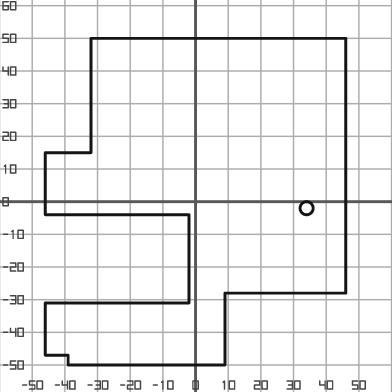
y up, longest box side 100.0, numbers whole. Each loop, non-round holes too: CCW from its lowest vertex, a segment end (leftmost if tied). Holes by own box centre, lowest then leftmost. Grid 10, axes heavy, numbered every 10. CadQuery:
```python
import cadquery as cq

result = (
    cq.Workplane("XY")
    .moveTo(-39.0, -50.0)
    .lineTo(9.0, -50.0)
    .lineTo(9.0, -28.0)
    .lineTo(46.0, -28.0)
    .lineTo(46.0, 50.0)
    .lineTo(-32.0, 50.0)
    .lineTo(-32.0, 15.0)
    .lineTo(-46.0, 15.0)
    .lineTo(-46.0, -4.0)
    .lineTo(-2.0, -4.0)
    .lineTo(-2.0, -31.0)
    .lineTo(-46.0, -31.0)
    .lineTo(-46.0, -47.0)
    .lineTo(-39.0, -47.0)
    .close()
    .moveTo(34.0, -2.0)
    .circle(2.0)
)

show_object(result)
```